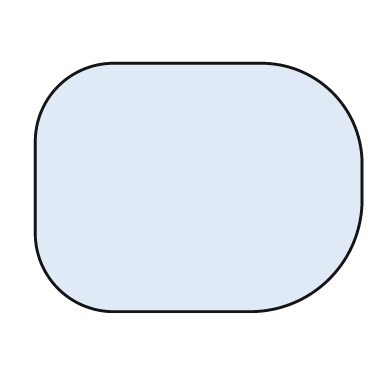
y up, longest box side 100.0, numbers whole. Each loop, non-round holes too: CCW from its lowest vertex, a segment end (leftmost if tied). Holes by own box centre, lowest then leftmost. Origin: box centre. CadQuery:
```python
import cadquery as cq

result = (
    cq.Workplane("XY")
    .moveTo(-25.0, -38.0)
    .lineTo(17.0, -38.0)
    .threePointArc((40.0, -28.0), (50.0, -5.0))
    .lineTo(50.0, 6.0)
    .threePointArc((41.0, 29.0), (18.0, 38.0))
    .lineTo(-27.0, 38.0)
    .threePointArc((-43.0, 31.0), (-50.0, 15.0))
    .lineTo(-50.0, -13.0)
    .threePointArc((-43.0, -31.0), (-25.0, -38.0))
    .close()
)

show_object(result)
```